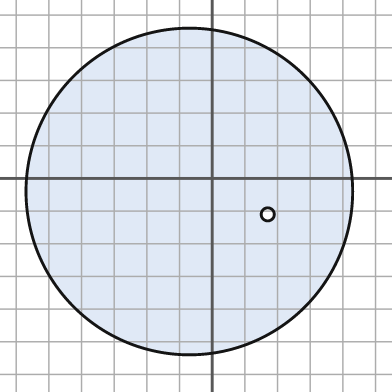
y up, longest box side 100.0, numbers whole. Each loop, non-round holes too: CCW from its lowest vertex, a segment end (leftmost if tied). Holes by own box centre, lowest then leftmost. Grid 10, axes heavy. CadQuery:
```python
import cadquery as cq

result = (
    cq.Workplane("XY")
    .moveTo(-7.0, -4.0)
    .circle(50.0)
    .moveTo(17.0, -11.0)
    .circle(2.0)
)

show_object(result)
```